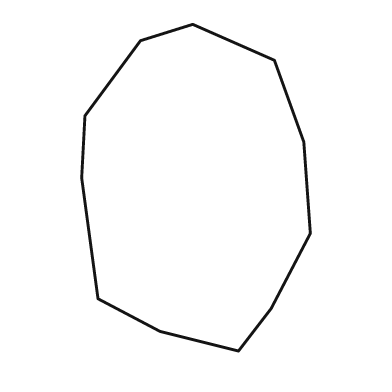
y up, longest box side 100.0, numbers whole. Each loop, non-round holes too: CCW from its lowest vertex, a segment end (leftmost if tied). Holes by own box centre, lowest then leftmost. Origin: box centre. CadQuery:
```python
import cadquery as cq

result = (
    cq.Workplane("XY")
    .moveTo(13.0, -50.0)
    .lineTo(23.0, -37.0)
    .lineTo(35.0, -14.0)
    .lineTo(33.0, 14.0)
    .lineTo(24.0, 39.0)
    .lineTo(-1.0, 50.0)
    .lineTo(-17.0, 45.0)
    .lineTo(-34.0, 22.0)
    .lineTo(-35.0, 3.0)
    .lineTo(-30.0, -34.0)
    .lineTo(-11.0, -44.0)
    .close()
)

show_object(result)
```